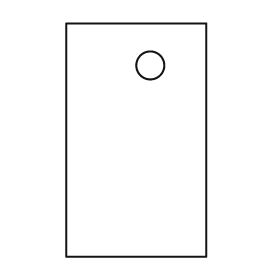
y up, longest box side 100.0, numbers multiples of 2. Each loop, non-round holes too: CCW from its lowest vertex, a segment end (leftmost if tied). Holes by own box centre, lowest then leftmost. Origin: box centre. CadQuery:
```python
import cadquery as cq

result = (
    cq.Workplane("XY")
    .moveTo(-30.0, -50.0)
    .lineTo(30.0, -50.0)
    .lineTo(30.0, 50.0)
    .lineTo(-30.0, 50.0)
    .close()
    .moveTo(6.0, 32.0)
    .circle(6.0)
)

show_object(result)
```